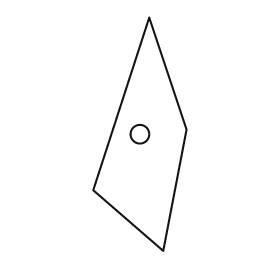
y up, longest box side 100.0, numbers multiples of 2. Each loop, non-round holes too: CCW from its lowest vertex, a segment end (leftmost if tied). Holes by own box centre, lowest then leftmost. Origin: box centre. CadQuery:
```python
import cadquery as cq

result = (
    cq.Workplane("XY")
    .moveTo(10.0, -50.0)
    .lineTo(20.0, 2.0)
    .lineTo(4.0, 50.0)
    .lineTo(-20.0, -24.0)
    .close()
    .moveTo(0.0, 0.0)
    .circle(4.0)
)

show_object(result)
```